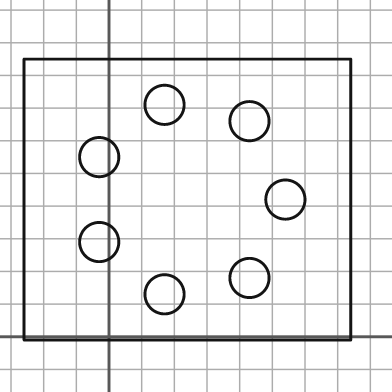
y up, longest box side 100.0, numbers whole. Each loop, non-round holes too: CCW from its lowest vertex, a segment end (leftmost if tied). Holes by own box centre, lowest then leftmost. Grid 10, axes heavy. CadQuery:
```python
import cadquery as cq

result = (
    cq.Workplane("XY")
    .moveTo(-26.0, -1.0)
    .lineTo(74.0, -1.0)
    .lineTo(74.0, 85.0)
    .lineTo(-26.0, 85.0)
    .close()
    .moveTo(17.0, 13.0)
    .circle(6.0)
    .moveTo(43.0, 18.0)
    .circle(6.0)
    .moveTo(-3.0, 29.0)
    .circle(6.0)
    .moveTo(54.0, 42.0)
    .circle(6.0)
    .moveTo(-3.0, 55.0)
    .circle(6.0)
    .moveTo(43.0, 66.0)
    .circle(6.0)
    .moveTo(17.0, 71.0)
    .circle(6.0)
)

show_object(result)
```